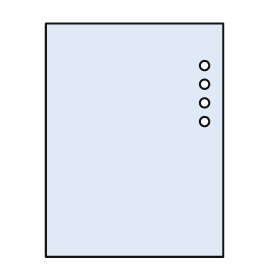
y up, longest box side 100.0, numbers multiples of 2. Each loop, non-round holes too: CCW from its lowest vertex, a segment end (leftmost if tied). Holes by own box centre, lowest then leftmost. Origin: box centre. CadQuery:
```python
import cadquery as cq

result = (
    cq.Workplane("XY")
    .moveTo(-38.0, -50.0)
    .lineTo(38.0, -50.0)
    .lineTo(38.0, 50.0)
    .lineTo(-38.0, 50.0)
    .close()
    .moveTo(30.0, 8.0)
    .circle(2.0)
    .moveTo(30.0, 16.0)
    .circle(2.0)
    .moveTo(30.0, 24.0)
    .circle(2.0)
    .moveTo(30.0, 32.0)
    .circle(2.0)
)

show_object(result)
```